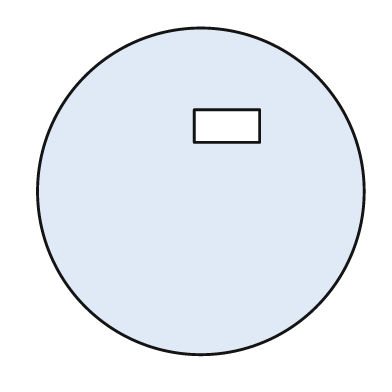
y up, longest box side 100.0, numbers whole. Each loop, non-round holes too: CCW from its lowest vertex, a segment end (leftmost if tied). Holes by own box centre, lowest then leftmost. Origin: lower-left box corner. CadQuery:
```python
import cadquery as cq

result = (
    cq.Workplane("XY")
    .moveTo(50.0, 50.0)
    .circle(50.0)
    .moveTo(48.0, 65.0)
    .lineTo(68.0, 65.0)
    .lineTo(68.0, 75.0)
    .lineTo(48.0, 75.0)
    .close()
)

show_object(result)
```